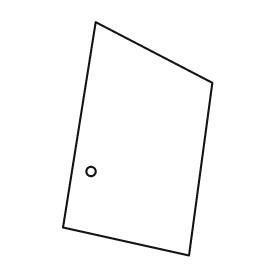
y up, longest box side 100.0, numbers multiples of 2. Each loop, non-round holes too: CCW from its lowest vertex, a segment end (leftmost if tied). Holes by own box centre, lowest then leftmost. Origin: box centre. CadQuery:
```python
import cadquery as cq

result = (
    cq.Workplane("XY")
    .moveTo(22.0, -50.0)
    .lineTo(32.0, 24.0)
    .lineTo(-18.0, 50.0)
    .lineTo(-32.0, -38.0)
    .close()
    .moveTo(-20.0, -14.0)
    .circle(2.0)
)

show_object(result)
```